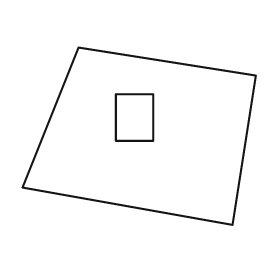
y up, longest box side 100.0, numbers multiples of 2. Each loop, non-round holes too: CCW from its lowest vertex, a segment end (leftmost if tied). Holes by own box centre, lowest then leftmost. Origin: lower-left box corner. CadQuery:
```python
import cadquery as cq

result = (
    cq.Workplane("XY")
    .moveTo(90.0, 0.0)
    .lineTo(100.0, 64.0)
    .lineTo(24.0, 76.0)
    .lineTo(0.0, 16.0)
    .close()
    .moveTo(40.0, 36.0)
    .lineTo(56.0, 36.0)
    .lineTo(56.0, 56.0)
    .lineTo(40.0, 56.0)
    .close()
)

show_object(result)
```